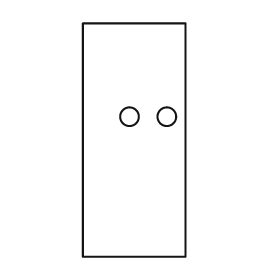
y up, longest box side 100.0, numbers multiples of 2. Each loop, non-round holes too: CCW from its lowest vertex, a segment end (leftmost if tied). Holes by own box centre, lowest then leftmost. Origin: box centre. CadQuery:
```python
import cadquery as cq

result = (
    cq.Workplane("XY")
    .moveTo(-22.0, -50.0)
    .lineTo(22.0, -50.0)
    .lineTo(22.0, 50.0)
    .lineTo(-22.0, 50.0)
    .close()
    .moveTo(-2.0, 10.0)
    .circle(4.0)
    .moveTo(14.0, 10.0)
    .circle(4.0)
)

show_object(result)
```